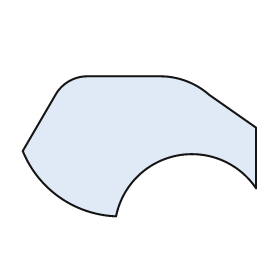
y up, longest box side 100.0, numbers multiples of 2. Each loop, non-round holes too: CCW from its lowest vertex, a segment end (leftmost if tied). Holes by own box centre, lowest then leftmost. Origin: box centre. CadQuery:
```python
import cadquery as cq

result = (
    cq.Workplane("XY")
    .moveTo(-10.0, -30.0)
    .threePointArc((16.0, -4.0), (50.0, -18.0))
    .lineTo(50.0, 8.0)
    .lineTo(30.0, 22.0)
    .threePointArc((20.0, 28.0), (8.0, 30.0))
    .lineTo(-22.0, 30.0)
    .threePointArc((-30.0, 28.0), (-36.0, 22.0))
    .lineTo(-50.0, -2.0)
    .threePointArc((-34.0, -22.0), (-10.0, -30.0))
    .close()
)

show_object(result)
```